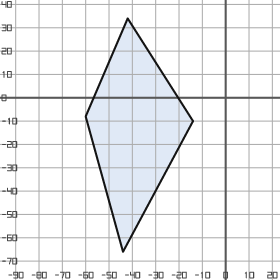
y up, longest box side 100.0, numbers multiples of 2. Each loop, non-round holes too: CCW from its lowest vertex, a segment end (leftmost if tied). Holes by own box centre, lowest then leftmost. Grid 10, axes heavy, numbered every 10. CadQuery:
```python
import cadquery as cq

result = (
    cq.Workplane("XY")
    .moveTo(-44.0, -66.0)
    .lineTo(-14.0, -10.0)
    .lineTo(-42.0, 34.0)
    .lineTo(-60.0, -8.0)
    .close()
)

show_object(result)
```